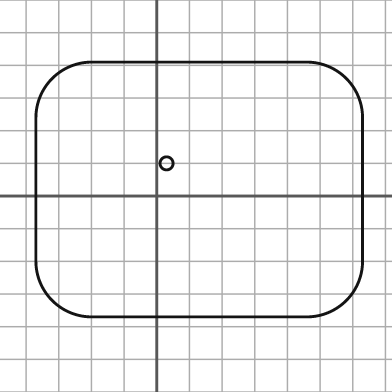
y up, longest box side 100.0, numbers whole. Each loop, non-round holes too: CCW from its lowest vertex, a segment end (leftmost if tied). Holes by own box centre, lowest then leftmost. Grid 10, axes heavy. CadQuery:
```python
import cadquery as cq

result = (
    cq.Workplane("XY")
    .moveTo(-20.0, -37.0)
    .lineTo(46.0, -37.0)
    .threePointArc((58.0, -32.0), (63.0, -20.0))
    .lineTo(63.0, 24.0)
    .threePointArc((58.0, 36.0), (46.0, 41.0))
    .lineTo(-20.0, 41.0)
    .threePointArc((-32.0, 36.0), (-37.0, 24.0))
    .lineTo(-37.0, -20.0)
    .threePointArc((-32.0, -32.0), (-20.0, -37.0))
    .close()
    .moveTo(3.0, 10.0)
    .circle(2.0)
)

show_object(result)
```